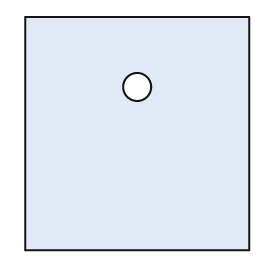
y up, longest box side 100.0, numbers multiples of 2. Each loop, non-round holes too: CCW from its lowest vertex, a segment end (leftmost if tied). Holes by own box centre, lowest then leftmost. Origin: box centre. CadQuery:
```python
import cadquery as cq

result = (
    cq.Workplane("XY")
    .moveTo(-48.0, -50.0)
    .lineTo(48.0, -50.0)
    .lineTo(48.0, 50.0)
    .lineTo(-48.0, 50.0)
    .close()
    .moveTo(0.0, 20.0)
    .circle(6.0)
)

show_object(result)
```